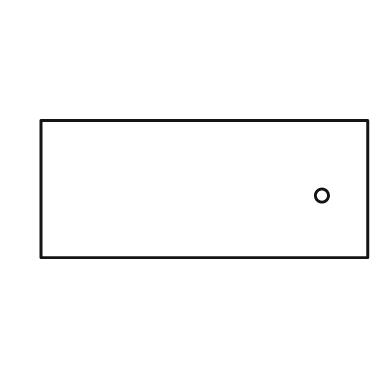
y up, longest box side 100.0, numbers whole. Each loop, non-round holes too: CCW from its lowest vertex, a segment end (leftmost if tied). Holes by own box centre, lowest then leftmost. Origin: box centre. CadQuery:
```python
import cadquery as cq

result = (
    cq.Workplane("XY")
    .moveTo(-50.0, -21.0)
    .lineTo(50.0, -21.0)
    .lineTo(50.0, 21.0)
    .lineTo(-50.0, 21.0)
    .close()
    .moveTo(36.0, -2.0)
    .circle(2.0)
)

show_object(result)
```